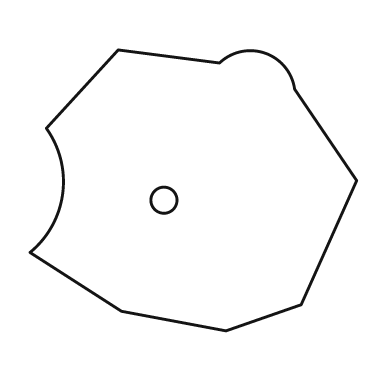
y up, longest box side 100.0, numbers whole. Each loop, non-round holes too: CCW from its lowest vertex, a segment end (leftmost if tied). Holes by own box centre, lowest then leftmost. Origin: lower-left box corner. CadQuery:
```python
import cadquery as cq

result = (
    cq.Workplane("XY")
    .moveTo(60.0, 0.0)
    .lineTo(83.0, 8.0)
    .lineTo(100.0, 46.0)
    .lineTo(81.0, 74.0)
    .threePointArc((72.0, 85.0), (58.0, 82.0))
    .lineTo(27.0, 86.0)
    .lineTo(5.0, 62.0)
    .threePointArc((10.0, 42.0), (0.0, 24.0))
    .lineTo(28.0, 6.0)
    .close()
    .moveTo(41.0, 40.0)
    .circle(4.0)
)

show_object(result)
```